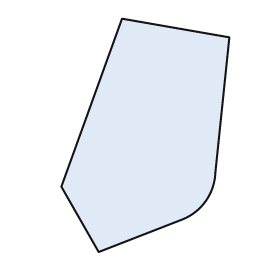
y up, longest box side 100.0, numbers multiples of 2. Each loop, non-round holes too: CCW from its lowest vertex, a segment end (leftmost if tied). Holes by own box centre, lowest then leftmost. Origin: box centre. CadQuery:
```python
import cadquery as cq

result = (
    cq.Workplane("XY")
    .moveTo(-20.0, -50.0)
    .lineTo(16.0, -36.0)
    .threePointArc((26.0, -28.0), (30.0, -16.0))
    .lineTo(36.0, 42.0)
    .lineTo(-10.0, 50.0)
    .lineTo(-36.0, -22.0)
    .close()
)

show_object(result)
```